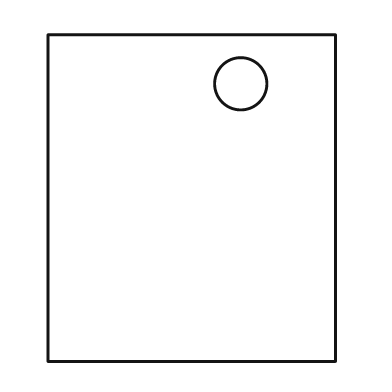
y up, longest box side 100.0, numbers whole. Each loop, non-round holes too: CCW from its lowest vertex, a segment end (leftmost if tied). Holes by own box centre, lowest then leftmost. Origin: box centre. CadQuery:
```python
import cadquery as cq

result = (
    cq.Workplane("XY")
    .moveTo(-44.0, -50.0)
    .lineTo(44.0, -50.0)
    .lineTo(44.0, 50.0)
    .lineTo(-44.0, 50.0)
    .close()
    .moveTo(15.0, 35.0)
    .circle(8.0)
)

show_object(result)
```